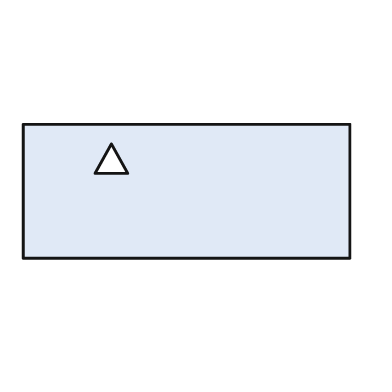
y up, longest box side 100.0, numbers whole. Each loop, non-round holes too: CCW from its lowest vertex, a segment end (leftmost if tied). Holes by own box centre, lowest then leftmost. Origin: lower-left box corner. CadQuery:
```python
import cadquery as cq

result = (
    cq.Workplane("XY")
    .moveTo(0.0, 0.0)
    .lineTo(100.0, 0.0)
    .lineTo(100.0, 41.0)
    .lineTo(0.0, 41.0)
    .close()
    .moveTo(22.0, 26.0)
    .lineTo(32.0, 26.0)
    .lineTo(27.0, 35.0)
    .close()
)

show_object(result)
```